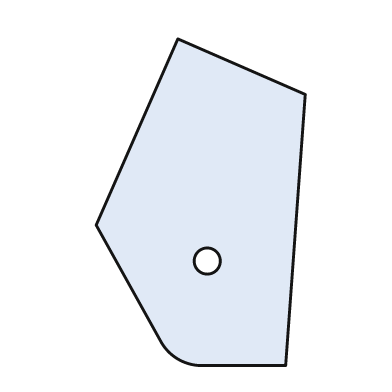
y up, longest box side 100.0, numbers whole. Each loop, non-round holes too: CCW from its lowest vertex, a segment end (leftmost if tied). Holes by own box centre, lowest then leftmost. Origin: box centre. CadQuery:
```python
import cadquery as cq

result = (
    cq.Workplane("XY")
    .moveTo(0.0, -50.0)
    .lineTo(26.0, -50.0)
    .lineTo(32.0, 33.0)
    .lineTo(-7.0, 50.0)
    .lineTo(-32.0, -7.0)
    .lineTo(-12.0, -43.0)
    .threePointArc((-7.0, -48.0), (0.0, -50.0))
    .close()
    .moveTo(2.0, -18.0)
    .circle(4.0)
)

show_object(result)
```